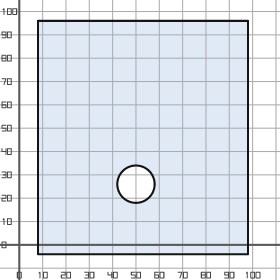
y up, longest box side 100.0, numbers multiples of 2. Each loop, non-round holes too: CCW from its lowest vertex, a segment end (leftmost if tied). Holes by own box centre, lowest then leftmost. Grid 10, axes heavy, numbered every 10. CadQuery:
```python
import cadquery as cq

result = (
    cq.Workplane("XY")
    .moveTo(8.0, -4.0)
    .lineTo(98.0, -4.0)
    .lineTo(98.0, 96.0)
    .lineTo(8.0, 96.0)
    .close()
    .moveTo(50.0, 26.0)
    .circle(8.0)
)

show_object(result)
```